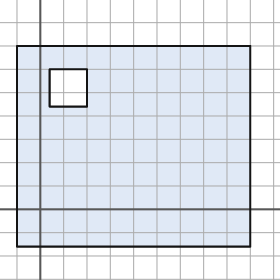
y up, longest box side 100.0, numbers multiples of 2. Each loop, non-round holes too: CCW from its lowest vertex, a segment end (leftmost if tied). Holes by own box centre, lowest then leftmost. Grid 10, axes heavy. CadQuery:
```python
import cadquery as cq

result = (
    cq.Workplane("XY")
    .moveTo(-10.0, -16.0)
    .lineTo(90.0, -16.0)
    .lineTo(90.0, 70.0)
    .lineTo(-10.0, 70.0)
    .close()
    .moveTo(4.0, 44.0)
    .lineTo(20.0, 44.0)
    .lineTo(20.0, 60.0)
    .lineTo(4.0, 60.0)
    .close()
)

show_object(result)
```